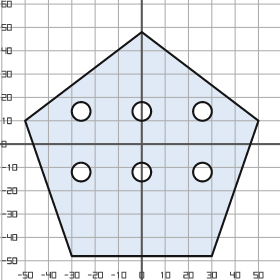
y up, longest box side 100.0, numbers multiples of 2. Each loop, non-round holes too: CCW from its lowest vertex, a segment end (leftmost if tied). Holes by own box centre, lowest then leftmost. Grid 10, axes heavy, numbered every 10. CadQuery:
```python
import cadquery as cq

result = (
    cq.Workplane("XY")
    .moveTo(-30.0, -48.0)
    .lineTo(30.0, -48.0)
    .lineTo(50.0, 10.0)
    .lineTo(0.0, 48.0)
    .lineTo(-50.0, 10.0)
    .close()
    .moveTo(-26.0, -12.0)
    .circle(4.0)
    .moveTo(0.0, -12.0)
    .circle(4.0)
    .moveTo(26.0, -12.0)
    .circle(4.0)
    .moveTo(-26.0, 14.0)
    .circle(4.0)
    .moveTo(0.0, 14.0)
    .circle(4.0)
    .moveTo(26.0, 14.0)
    .circle(4.0)
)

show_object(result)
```